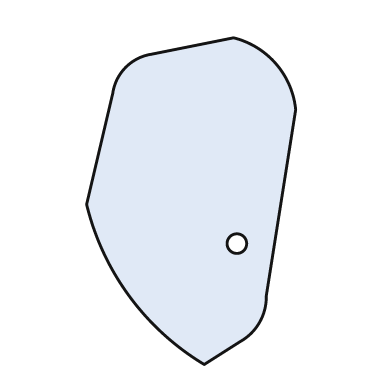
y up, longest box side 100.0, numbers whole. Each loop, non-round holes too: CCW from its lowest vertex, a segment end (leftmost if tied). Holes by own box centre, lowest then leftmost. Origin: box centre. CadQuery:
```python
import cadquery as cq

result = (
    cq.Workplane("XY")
    .moveTo(4.0, -50.0)
    .lineTo(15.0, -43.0)
    .threePointArc((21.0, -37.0), (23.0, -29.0))
    .lineTo(32.0, 28.0)
    .threePointArc((26.0, 42.0), (13.0, 50.0))
    .lineTo(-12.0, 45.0)
    .threePointArc((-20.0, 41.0), (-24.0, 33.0))
    .lineTo(-32.0, -1.0)
    .threePointArc((-19.0, -29.0), (4.0, -50.0))
    .close()
    .moveTo(14.0, -13.0)
    .circle(3.0)
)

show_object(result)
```